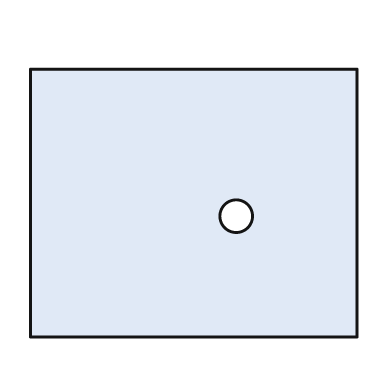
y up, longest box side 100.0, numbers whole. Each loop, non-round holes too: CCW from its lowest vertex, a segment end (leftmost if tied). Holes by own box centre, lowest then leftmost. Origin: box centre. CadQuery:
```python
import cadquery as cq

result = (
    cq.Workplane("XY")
    .moveTo(-50.0, -41.0)
    .lineTo(50.0, -41.0)
    .lineTo(50.0, 41.0)
    .lineTo(-50.0, 41.0)
    .close()
    .moveTo(13.0, -4.0)
    .circle(5.0)
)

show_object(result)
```